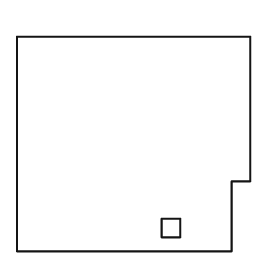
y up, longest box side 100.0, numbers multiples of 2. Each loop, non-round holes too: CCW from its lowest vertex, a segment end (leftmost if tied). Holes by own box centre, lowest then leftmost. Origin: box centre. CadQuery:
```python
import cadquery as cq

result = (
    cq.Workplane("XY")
    .moveTo(-50.0, -46.0)
    .lineTo(42.0, -46.0)
    .lineTo(42.0, -16.0)
    .lineTo(50.0, -16.0)
    .lineTo(50.0, 46.0)
    .lineTo(-50.0, 46.0)
    .close()
    .moveTo(12.0, -40.0)
    .lineTo(20.0, -40.0)
    .lineTo(20.0, -32.0)
    .lineTo(12.0, -32.0)
    .close()
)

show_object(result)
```